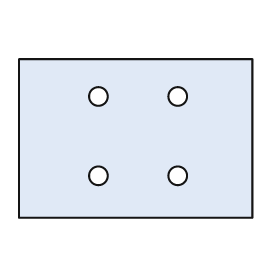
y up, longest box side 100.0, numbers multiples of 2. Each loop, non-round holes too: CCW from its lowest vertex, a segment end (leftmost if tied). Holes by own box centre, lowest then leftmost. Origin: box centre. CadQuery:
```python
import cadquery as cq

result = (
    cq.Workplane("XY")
    .moveTo(-50.0, -34.0)
    .lineTo(50.0, -34.0)
    .lineTo(50.0, 34.0)
    .lineTo(-50.0, 34.0)
    .close()
    .moveTo(-16.0, -16.0)
    .circle(4.0)
    .moveTo(18.0, -16.0)
    .circle(4.0)
    .moveTo(-16.0, 18.0)
    .circle(4.0)
    .moveTo(18.0, 18.0)
    .circle(4.0)
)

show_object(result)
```